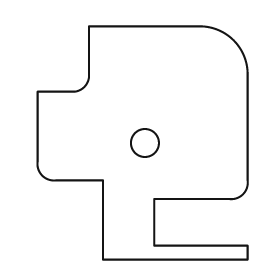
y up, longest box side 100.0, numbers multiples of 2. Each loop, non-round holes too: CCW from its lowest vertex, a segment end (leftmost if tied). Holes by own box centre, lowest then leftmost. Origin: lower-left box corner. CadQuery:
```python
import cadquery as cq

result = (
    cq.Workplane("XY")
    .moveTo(28.0, 0.0)
    .lineTo(90.0, 0.0)
    .lineTo(90.0, 6.0)
    .lineTo(50.0, 6.0)
    .lineTo(50.0, 26.0)
    .lineTo(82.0, 26.0)
    .threePointArc((88.0, 28.0), (90.0, 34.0))
    .lineTo(90.0, 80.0)
    .threePointArc((84.0, 94.0), (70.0, 100.0))
    .lineTo(22.0, 100.0)
    .lineTo(22.0, 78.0)
    .threePointArc((20.0, 74.0), (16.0, 72.0))
    .lineTo(0.0, 72.0)
    .lineTo(0.0, 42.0)
    .threePointArc((2.0, 36.0), (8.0, 34.0))
    .lineTo(28.0, 34.0)
    .close()
    .moveTo(46.0, 50.0)
    .circle(6.0)
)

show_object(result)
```